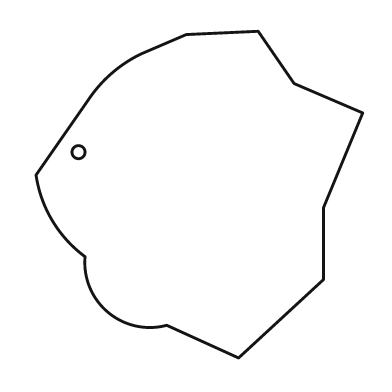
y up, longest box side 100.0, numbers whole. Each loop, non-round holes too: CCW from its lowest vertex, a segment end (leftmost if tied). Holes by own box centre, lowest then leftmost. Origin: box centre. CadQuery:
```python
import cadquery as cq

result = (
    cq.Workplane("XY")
    .moveTo(12.0, -50.0)
    .lineTo(38.0, -26.0)
    .lineTo(38.0, -4.0)
    .lineTo(50.0, 25.0)
    .lineTo(29.0, 34.0)
    .lineTo(18.0, 50.0)
    .lineTo(-4.0, 49.0)
    .lineTo(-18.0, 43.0)
    .threePointArc((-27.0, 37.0), (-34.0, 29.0))
    .lineTo(-50.0, 6.0)
    .threePointArc((-45.0, -8.0), (-35.0, -19.0))
    .threePointArc((-28.0, -36.0), (-10.0, -40.0))
    .close()
    .moveTo(-37.0, 13.0)
    .circle(2.0)
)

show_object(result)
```